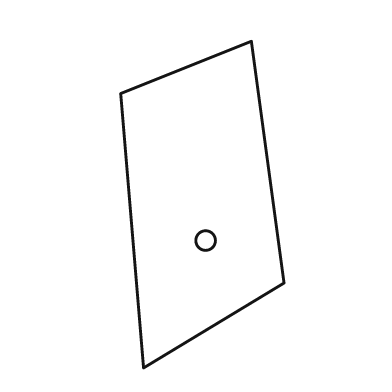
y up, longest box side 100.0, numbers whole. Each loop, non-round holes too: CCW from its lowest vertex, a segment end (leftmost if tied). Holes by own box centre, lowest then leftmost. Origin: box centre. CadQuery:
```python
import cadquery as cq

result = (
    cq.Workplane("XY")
    .moveTo(-18.0, -50.0)
    .lineTo(25.0, -24.0)
    .lineTo(15.0, 50.0)
    .lineTo(-25.0, 34.0)
    .close()
    .moveTo(1.0, -11.0)
    .circle(3.0)
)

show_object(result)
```